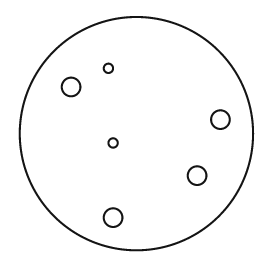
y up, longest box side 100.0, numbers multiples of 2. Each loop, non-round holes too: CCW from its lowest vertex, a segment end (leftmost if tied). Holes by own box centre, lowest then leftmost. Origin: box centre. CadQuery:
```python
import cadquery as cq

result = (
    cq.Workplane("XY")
    .moveTo(0.0, 0.0)
    .circle(50.0)
    .moveTo(-10.0, -36.0)
    .circle(4.0)
    .moveTo(26.0, -18.0)
    .circle(4.0)
    .moveTo(-10.0, -4.0)
    .circle(2.0)
    .moveTo(36.0, 6.0)
    .circle(4.0)
    .moveTo(-28.0, 20.0)
    .circle(4.0)
    .moveTo(-12.0, 28.0)
    .circle(2.0)
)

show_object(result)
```